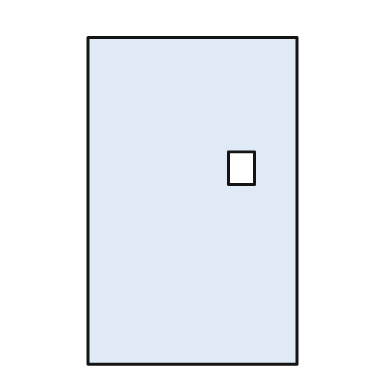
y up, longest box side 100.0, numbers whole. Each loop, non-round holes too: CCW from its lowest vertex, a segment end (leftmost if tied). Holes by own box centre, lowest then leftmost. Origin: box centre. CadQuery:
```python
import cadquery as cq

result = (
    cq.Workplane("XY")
    .moveTo(-32.0, -50.0)
    .lineTo(32.0, -50.0)
    .lineTo(32.0, 50.0)
    .lineTo(-32.0, 50.0)
    .close()
    .moveTo(11.0, 5.0)
    .lineTo(19.0, 5.0)
    .lineTo(19.0, 15.0)
    .lineTo(11.0, 15.0)
    .close()
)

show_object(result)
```